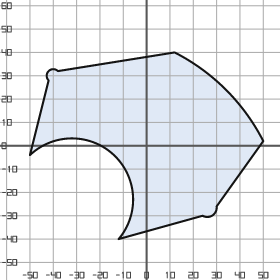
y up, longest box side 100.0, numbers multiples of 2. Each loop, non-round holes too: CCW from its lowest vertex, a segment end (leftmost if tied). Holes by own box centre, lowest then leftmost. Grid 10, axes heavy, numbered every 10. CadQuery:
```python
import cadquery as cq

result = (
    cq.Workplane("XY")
    .moveTo(-12.0, -40.0)
    .lineTo(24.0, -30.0)
    .threePointArc((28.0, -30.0), (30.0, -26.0))
    .lineTo(50.0, 2.0)
    .threePointArc((34.0, 24.0), (12.0, 40.0))
    .lineTo(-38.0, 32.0)
    .threePointArc((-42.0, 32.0), (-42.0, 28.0))
    .lineTo(-50.0, -4.0)
    .threePointArc((-14.0, -4.0), (-12.0, -40.0))
    .close()
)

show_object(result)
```